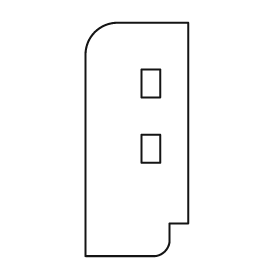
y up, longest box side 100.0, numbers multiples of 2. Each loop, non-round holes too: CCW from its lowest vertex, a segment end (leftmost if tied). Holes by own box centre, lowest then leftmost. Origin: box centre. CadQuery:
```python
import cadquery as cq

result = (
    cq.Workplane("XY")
    .moveTo(-22.0, -50.0)
    .lineTo(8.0, -50.0)
    .threePointArc((12.0, -48.0), (14.0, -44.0))
    .lineTo(14.0, -36.0)
    .lineTo(22.0, -36.0)
    .lineTo(22.0, 50.0)
    .lineTo(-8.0, 50.0)
    .threePointArc((-18.0, 46.0), (-22.0, 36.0))
    .close()
    .moveTo(2.0, -10.0)
    .lineTo(10.0, -10.0)
    .lineTo(10.0, 2.0)
    .lineTo(2.0, 2.0)
    .close()
    .moveTo(2.0, 18.0)
    .lineTo(10.0, 18.0)
    .lineTo(10.0, 30.0)
    .lineTo(2.0, 30.0)
    .close()
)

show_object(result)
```